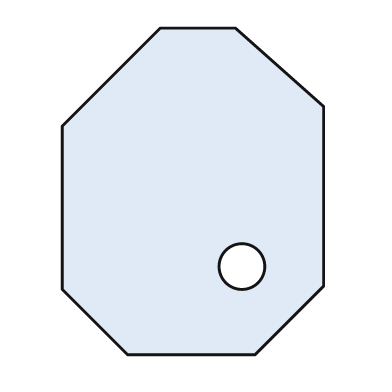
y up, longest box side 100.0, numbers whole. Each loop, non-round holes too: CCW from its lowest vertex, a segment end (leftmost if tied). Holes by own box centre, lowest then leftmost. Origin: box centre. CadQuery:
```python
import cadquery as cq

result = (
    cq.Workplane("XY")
    .moveTo(-20.0, -50.0)
    .lineTo(19.0, -50.0)
    .lineTo(40.0, -29.0)
    .lineTo(40.0, 26.0)
    .lineTo(13.0, 50.0)
    .lineTo(-10.0, 50.0)
    .lineTo(-40.0, 20.0)
    .lineTo(-40.0, -30.0)
    .close()
    .moveTo(15.0, -23.0)
    .circle(7.0)
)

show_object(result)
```